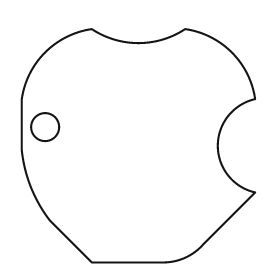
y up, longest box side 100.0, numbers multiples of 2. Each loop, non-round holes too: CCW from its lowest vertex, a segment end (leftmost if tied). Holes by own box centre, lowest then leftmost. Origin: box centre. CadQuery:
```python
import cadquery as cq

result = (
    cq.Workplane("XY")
    .moveTo(-20.0, -50.0)
    .lineTo(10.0, -50.0)
    .threePointArc((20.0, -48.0), (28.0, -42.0))
    .lineTo(50.0, -20.0)
    .threePointArc((34.0, 0.0), (50.0, 20.0))
    .threePointArc((40.0, 40.0), (20.0, 50.0))
    .threePointArc((0.0, 44.0), (-20.0, 50.0))
    .threePointArc((-40.0, 40.0), (-50.0, 20.0))
    .lineTo(-50.0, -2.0)
    .threePointArc((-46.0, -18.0), (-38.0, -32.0))
    .close()
    .moveTo(-40.0, 8.0)
    .circle(6.0)
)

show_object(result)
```